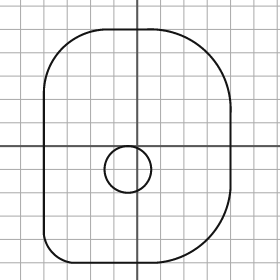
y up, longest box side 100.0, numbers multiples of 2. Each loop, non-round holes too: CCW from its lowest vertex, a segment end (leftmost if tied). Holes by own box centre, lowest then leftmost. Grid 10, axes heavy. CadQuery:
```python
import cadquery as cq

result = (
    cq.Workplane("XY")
    .moveTo(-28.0, -50.0)
    .lineTo(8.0, -50.0)
    .threePointArc((30.0, -40.0), (40.0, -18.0))
    .lineTo(40.0, 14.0)
    .threePointArc((30.0, 40.0), (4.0, 50.0))
    .lineTo(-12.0, 50.0)
    .threePointArc((-32.0, 42.0), (-40.0, 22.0))
    .lineTo(-40.0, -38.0)
    .threePointArc((-36.0, -46.0), (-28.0, -50.0))
    .close()
    .moveTo(-4.0, -10.0)
    .circle(10.0)
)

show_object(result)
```